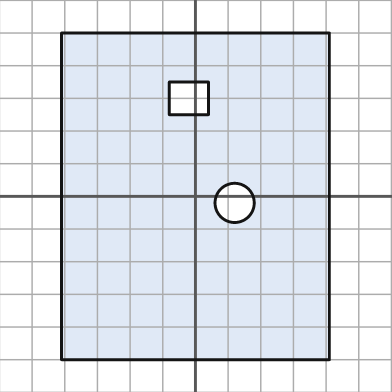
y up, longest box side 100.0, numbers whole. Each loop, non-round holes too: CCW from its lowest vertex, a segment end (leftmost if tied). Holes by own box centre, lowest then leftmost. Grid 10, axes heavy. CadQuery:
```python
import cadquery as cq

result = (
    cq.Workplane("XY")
    .moveTo(-41.0, -50.0)
    .lineTo(41.0, -50.0)
    .lineTo(41.0, 50.0)
    .lineTo(-41.0, 50.0)
    .close()
    .moveTo(12.0, -2.0)
    .circle(6.0)
    .moveTo(-8.0, 25.0)
    .lineTo(4.0, 25.0)
    .lineTo(4.0, 35.0)
    .lineTo(-8.0, 35.0)
    .close()
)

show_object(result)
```